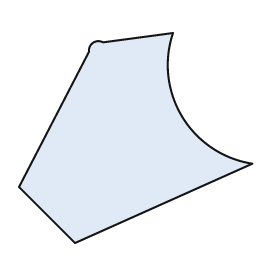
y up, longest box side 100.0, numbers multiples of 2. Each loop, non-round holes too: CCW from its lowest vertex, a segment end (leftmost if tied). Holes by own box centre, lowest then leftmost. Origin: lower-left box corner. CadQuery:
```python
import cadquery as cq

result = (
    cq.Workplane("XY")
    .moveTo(24.0, 0.0)
    .lineTo(100.0, 34.0)
    .threePointArc((70.0, 54.0), (66.0, 90.0))
    .lineTo(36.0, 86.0)
    .threePointArc((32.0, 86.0), (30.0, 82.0))
    .lineTo(0.0, 24.0)
    .close()
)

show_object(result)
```